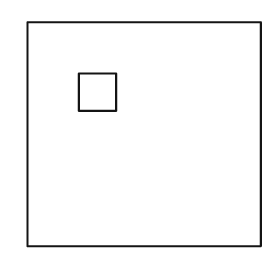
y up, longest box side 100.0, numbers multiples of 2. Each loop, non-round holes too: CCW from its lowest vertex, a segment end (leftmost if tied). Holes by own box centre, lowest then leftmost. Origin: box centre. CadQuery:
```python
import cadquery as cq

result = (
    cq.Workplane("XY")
    .moveTo(-50.0, -48.0)
    .lineTo(50.0, -48.0)
    .lineTo(50.0, 48.0)
    .lineTo(-50.0, 48.0)
    .close()
    .moveTo(-28.0, 10.0)
    .lineTo(-12.0, 10.0)
    .lineTo(-12.0, 26.0)
    .lineTo(-28.0, 26.0)
    .close()
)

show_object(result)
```